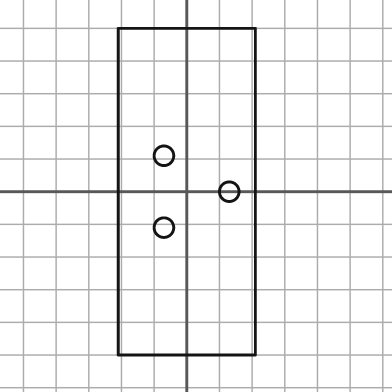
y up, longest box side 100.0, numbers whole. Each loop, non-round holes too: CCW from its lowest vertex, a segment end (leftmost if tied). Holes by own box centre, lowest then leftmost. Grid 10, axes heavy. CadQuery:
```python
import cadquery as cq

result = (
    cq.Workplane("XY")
    .moveTo(-21.0, -50.0)
    .lineTo(21.0, -50.0)
    .lineTo(21.0, 50.0)
    .lineTo(-21.0, 50.0)
    .close()
    .moveTo(-7.0, -11.0)
    .circle(3.0)
    .moveTo(13.0, 0.0)
    .circle(3.0)
    .moveTo(-7.0, 11.0)
    .circle(3.0)
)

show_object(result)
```